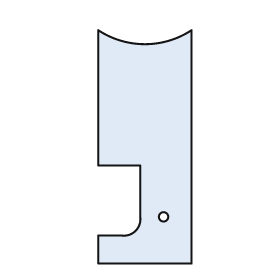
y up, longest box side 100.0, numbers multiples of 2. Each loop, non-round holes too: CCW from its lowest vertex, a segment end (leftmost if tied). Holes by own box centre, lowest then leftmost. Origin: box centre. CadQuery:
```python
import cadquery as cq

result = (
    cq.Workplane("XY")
    .moveTo(-20.0, -50.0)
    .lineTo(20.0, -50.0)
    .lineTo(20.0, 50.0)
    .threePointArc((0.0, 44.0), (-20.0, 50.0))
    .lineTo(-20.0, -8.0)
    .lineTo(-2.0, -8.0)
    .lineTo(-2.0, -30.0)
    .threePointArc((-4.0, -36.0), (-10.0, -38.0))
    .lineTo(-20.0, -38.0)
    .close()
    .moveTo(8.0, -30.0)
    .circle(2.0)
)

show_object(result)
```